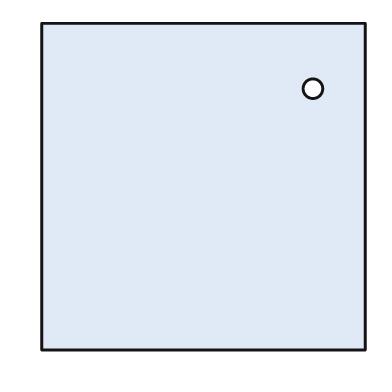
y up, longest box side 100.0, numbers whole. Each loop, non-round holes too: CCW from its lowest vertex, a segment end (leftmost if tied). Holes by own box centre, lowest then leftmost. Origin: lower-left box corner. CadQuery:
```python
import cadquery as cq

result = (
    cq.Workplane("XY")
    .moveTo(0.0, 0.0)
    .lineTo(99.0, 0.0)
    .lineTo(99.0, 100.0)
    .lineTo(0.0, 100.0)
    .close()
    .moveTo(83.0, 80.0)
    .circle(3.0)
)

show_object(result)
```